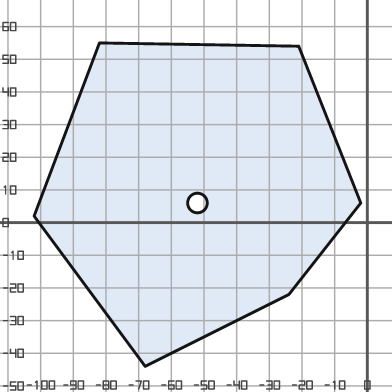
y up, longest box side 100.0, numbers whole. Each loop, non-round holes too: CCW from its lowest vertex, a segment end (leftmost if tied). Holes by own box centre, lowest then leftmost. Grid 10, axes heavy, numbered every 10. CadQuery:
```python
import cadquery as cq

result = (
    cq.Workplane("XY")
    .moveTo(-68.0, -44.0)
    .lineTo(-24.0, -22.0)
    .lineTo(-2.0, 6.0)
    .lineTo(-21.0, 54.0)
    .lineTo(-82.0, 55.0)
    .lineTo(-102.0, 2.0)
    .close()
    .moveTo(-52.0, 6.0)
    .circle(3.0)
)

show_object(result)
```